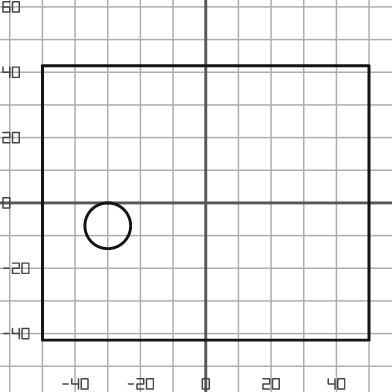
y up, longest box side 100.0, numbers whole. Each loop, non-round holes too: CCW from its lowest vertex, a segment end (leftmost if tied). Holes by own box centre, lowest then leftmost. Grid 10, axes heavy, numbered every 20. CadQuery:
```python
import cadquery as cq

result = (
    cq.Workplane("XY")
    .moveTo(-50.0, -42.0)
    .lineTo(50.0, -42.0)
    .lineTo(50.0, 42.0)
    .lineTo(-50.0, 42.0)
    .close()
    .moveTo(-30.0, -7.0)
    .circle(7.0)
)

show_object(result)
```